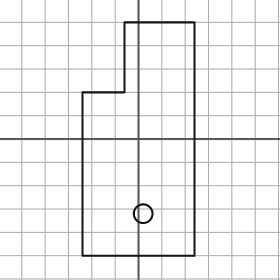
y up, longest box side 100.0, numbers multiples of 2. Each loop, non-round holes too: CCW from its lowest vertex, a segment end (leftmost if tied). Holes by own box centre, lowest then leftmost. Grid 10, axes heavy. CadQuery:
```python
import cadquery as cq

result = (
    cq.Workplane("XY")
    .moveTo(-24.0, -50.0)
    .lineTo(24.0, -50.0)
    .lineTo(24.0, 50.0)
    .lineTo(-6.0, 50.0)
    .lineTo(-6.0, 20.0)
    .lineTo(-24.0, 20.0)
    .close()
    .moveTo(2.0, -32.0)
    .circle(4.0)
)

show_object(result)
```